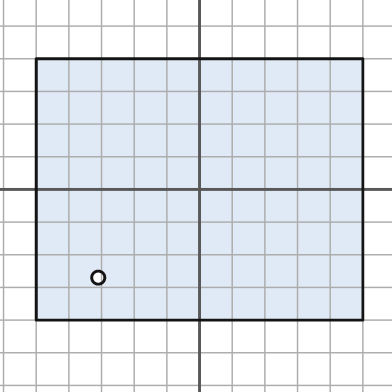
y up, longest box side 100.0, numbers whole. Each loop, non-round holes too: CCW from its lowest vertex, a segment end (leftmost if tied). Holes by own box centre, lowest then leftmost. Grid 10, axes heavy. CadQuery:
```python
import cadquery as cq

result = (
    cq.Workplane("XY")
    .moveTo(-50.0, -40.0)
    .lineTo(50.0, -40.0)
    .lineTo(50.0, 40.0)
    .lineTo(-50.0, 40.0)
    .close()
    .moveTo(-31.0, -27.0)
    .circle(2.0)
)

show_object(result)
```